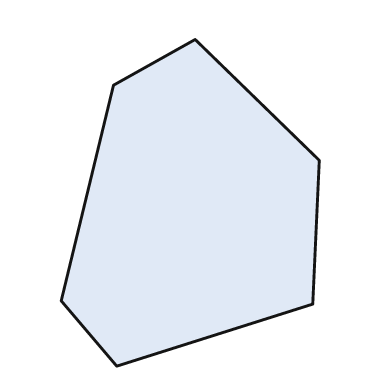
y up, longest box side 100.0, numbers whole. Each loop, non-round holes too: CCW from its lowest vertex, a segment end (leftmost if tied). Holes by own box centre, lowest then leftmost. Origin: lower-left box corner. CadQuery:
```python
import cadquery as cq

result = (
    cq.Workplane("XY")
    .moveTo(17.0, 0.0)
    .lineTo(77.0, 19.0)
    .lineTo(79.0, 63.0)
    .lineTo(41.0, 100.0)
    .lineTo(16.0, 86.0)
    .lineTo(0.0, 20.0)
    .close()
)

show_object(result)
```